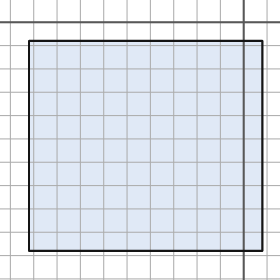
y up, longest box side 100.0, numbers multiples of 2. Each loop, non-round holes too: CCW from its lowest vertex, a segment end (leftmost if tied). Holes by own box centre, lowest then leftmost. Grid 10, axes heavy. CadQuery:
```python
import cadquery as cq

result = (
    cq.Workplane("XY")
    .moveTo(-92.0, -98.0)
    .lineTo(8.0, -98.0)
    .lineTo(8.0, -8.0)
    .lineTo(-92.0, -8.0)
    .close()
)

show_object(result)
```